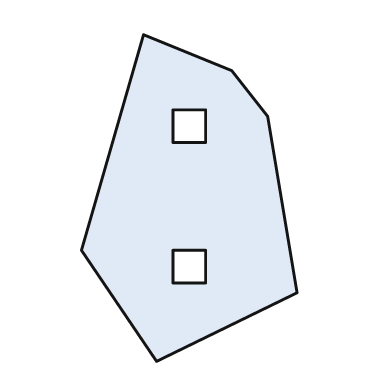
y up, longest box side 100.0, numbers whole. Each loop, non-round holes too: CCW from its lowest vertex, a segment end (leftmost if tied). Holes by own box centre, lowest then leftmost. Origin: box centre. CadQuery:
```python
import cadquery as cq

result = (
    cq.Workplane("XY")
    .moveTo(-10.0, -50.0)
    .lineTo(33.0, -29.0)
    .lineTo(24.0, 25.0)
    .lineTo(13.0, 39.0)
    .lineTo(-14.0, 50.0)
    .lineTo(-33.0, -16.0)
    .close()
    .moveTo(-5.0, -26.0)
    .lineTo(5.0, -26.0)
    .lineTo(5.0, -16.0)
    .lineTo(-5.0, -16.0)
    .close()
    .moveTo(-5.0, 17.0)
    .lineTo(5.0, 17.0)
    .lineTo(5.0, 27.0)
    .lineTo(-5.0, 27.0)
    .close()
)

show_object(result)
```